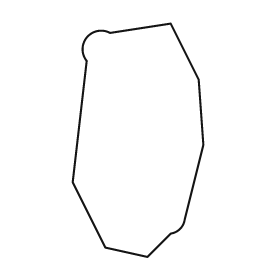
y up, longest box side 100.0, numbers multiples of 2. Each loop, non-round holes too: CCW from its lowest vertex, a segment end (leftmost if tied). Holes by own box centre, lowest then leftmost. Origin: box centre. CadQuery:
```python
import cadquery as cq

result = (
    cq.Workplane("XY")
    .moveTo(4.0, -50.0)
    .lineTo(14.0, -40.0)
    .threePointArc((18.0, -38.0), (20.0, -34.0))
    .lineTo(28.0, -2.0)
    .lineTo(26.0, 26.0)
    .lineTo(14.0, 50.0)
    .lineTo(-12.0, 46.0)
    .threePointArc((-22.0, 44.0), (-22.0, 34.0))
    .lineTo(-28.0, -18.0)
    .lineTo(-14.0, -46.0)
    .close()
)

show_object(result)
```